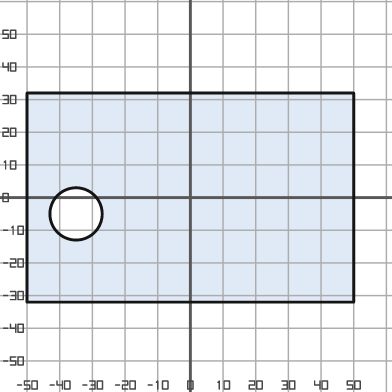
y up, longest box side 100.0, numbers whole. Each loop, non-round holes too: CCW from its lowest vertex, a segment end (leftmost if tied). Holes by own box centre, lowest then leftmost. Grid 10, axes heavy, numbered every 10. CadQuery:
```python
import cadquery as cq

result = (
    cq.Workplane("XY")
    .moveTo(-50.0, -32.0)
    .lineTo(50.0, -32.0)
    .lineTo(50.0, 32.0)
    .lineTo(-50.0, 32.0)
    .close()
    .moveTo(-35.0, -5.0)
    .circle(8.0)
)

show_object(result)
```